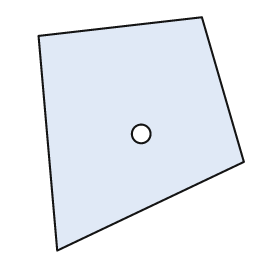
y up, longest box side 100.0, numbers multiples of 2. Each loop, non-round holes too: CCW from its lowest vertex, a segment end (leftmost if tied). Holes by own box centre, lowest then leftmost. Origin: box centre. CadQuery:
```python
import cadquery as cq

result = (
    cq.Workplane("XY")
    .moveTo(-36.0, -50.0)
    .lineTo(44.0, -12.0)
    .lineTo(26.0, 50.0)
    .lineTo(-44.0, 42.0)
    .close()
    .moveTo(0.0, 0.0)
    .circle(4.0)
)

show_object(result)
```